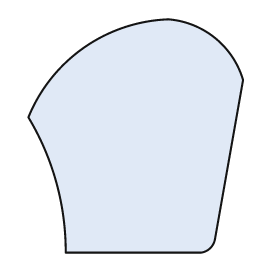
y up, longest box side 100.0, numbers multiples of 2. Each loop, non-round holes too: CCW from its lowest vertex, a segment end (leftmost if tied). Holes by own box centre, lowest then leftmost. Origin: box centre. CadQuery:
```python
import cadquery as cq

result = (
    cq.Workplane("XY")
    .moveTo(-30.0, -50.0)
    .lineTo(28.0, -50.0)
    .threePointArc((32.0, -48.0), (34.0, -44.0))
    .lineTo(46.0, 24.0)
    .threePointArc((34.0, 42.0), (14.0, 50.0))
    .threePointArc((-22.0, 38.0), (-46.0, 8.0))
    .threePointArc((-34.0, -20.0), (-30.0, -50.0))
    .close()
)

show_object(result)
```